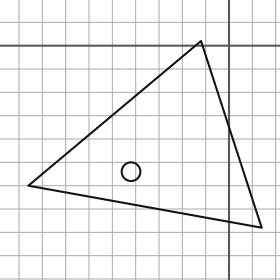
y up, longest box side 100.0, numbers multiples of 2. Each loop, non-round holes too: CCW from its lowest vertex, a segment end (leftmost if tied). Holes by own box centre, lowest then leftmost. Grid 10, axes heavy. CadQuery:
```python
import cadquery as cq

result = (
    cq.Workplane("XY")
    .moveTo(14.0, -78.0)
    .lineTo(-12.0, 2.0)
    .lineTo(-86.0, -60.0)
    .close()
    .moveTo(-42.0, -54.0)
    .circle(4.0)
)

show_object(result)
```